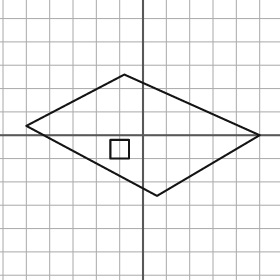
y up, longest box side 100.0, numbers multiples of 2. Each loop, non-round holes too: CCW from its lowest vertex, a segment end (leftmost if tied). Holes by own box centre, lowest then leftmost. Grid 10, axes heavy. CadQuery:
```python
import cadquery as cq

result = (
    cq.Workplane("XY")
    .moveTo(6.0, -26.0)
    .lineTo(50.0, 0.0)
    .lineTo(-8.0, 26.0)
    .lineTo(-50.0, 4.0)
    .close()
    .moveTo(-14.0, -10.0)
    .lineTo(-6.0, -10.0)
    .lineTo(-6.0, -2.0)
    .lineTo(-14.0, -2.0)
    .close()
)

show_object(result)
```